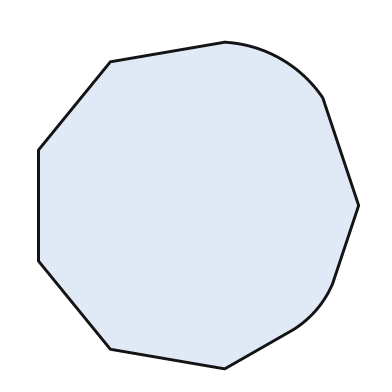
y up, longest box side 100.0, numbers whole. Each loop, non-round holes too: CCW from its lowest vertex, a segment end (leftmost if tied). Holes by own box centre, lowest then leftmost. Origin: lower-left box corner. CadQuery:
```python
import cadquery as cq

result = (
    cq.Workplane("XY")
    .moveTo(57.0, 0.0)
    .lineTo(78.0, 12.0)
    .threePointArc((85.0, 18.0), (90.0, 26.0))
    .lineTo(98.0, 50.0)
    .lineTo(87.0, 83.0)
    .threePointArc((74.0, 95.0), (57.0, 100.0))
    .lineTo(22.0, 94.0)
    .lineTo(0.0, 67.0)
    .lineTo(0.0, 33.0)
    .lineTo(22.0, 6.0)
    .close()
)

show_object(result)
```